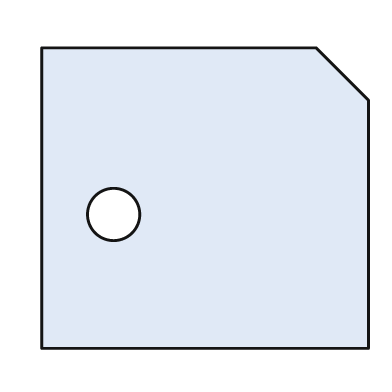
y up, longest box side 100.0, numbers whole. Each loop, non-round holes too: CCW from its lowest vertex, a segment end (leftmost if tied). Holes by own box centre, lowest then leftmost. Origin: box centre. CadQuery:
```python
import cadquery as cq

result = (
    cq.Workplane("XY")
    .moveTo(-50.0, -46.0)
    .lineTo(50.0, -46.0)
    .lineTo(50.0, 30.0)
    .lineTo(34.0, 46.0)
    .lineTo(-50.0, 46.0)
    .close()
    .moveTo(-28.0, -5.0)
    .circle(8.0)
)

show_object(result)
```